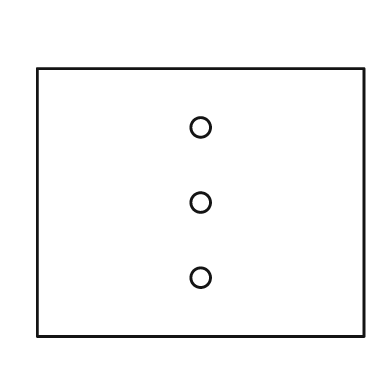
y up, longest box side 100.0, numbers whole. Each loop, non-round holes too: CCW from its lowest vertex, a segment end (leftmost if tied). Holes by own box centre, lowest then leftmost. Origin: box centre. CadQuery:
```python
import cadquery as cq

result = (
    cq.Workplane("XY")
    .moveTo(-50.0, -41.0)
    .lineTo(50.0, -41.0)
    .lineTo(50.0, 41.0)
    .lineTo(-50.0, 41.0)
    .close()
    .moveTo(0.0, -23.0)
    .circle(3.0)
    .moveTo(0.0, 0.0)
    .circle(3.0)
    .moveTo(0.0, 23.0)
    .circle(3.0)
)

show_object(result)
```